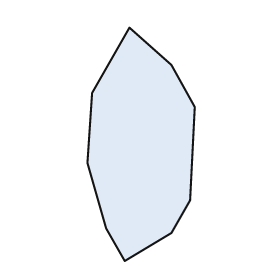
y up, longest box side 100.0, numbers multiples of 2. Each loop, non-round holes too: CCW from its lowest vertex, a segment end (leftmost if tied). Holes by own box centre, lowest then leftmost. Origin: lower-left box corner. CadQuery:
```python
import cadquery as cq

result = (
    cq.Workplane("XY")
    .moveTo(16.0, 0.0)
    .lineTo(36.0, 12.0)
    .lineTo(44.0, 26.0)
    .lineTo(46.0, 66.0)
    .lineTo(36.0, 84.0)
    .lineTo(18.0, 100.0)
    .lineTo(2.0, 72.0)
    .lineTo(0.0, 42.0)
    .lineTo(8.0, 14.0)
    .close()
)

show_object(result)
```